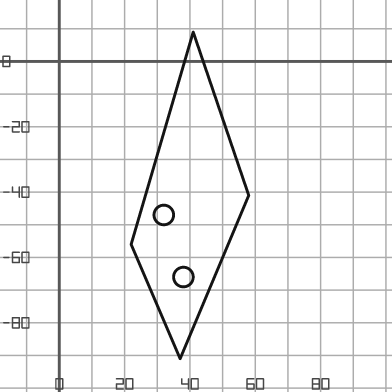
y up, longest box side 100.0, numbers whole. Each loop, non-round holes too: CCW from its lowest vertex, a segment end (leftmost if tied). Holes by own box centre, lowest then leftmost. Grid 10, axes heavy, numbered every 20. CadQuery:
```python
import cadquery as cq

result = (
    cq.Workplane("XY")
    .moveTo(37.0, -91.0)
    .lineTo(58.0, -41.0)
    .lineTo(41.0, 9.0)
    .lineTo(22.0, -56.0)
    .close()
    .moveTo(38.0, -66.0)
    .circle(3.0)
    .moveTo(32.0, -47.0)
    .circle(3.0)
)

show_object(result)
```